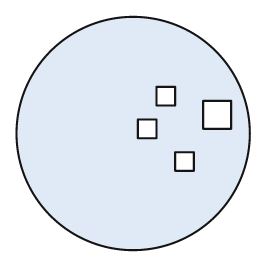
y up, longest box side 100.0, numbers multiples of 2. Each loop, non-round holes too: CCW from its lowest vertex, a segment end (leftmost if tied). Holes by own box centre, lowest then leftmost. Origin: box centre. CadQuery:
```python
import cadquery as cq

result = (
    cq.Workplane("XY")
    .moveTo(0.0, 0.0)
    .circle(50.0)
    .moveTo(18.0, -16.0)
    .lineTo(26.0, -16.0)
    .lineTo(26.0, -8.0)
    .lineTo(18.0, -8.0)
    .close()
    .moveTo(2.0, -2.0)
    .lineTo(10.0, -2.0)
    .lineTo(10.0, 6.0)
    .lineTo(2.0, 6.0)
    .close()
    .moveTo(30.0, 2.0)
    .lineTo(42.0, 2.0)
    .lineTo(42.0, 14.0)
    .lineTo(30.0, 14.0)
    .close()
    .moveTo(10.0, 12.0)
    .lineTo(18.0, 12.0)
    .lineTo(18.0, 20.0)
    .lineTo(10.0, 20.0)
    .close()
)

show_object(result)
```